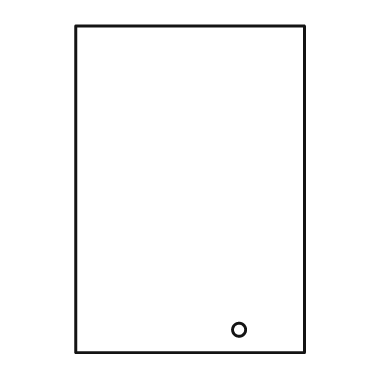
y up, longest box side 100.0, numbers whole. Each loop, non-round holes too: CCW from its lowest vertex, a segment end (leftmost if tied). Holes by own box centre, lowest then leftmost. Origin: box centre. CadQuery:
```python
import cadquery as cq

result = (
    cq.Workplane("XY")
    .moveTo(-35.0, -50.0)
    .lineTo(35.0, -50.0)
    .lineTo(35.0, 50.0)
    .lineTo(-35.0, 50.0)
    .close()
    .moveTo(15.0, -43.0)
    .circle(2.0)
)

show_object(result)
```